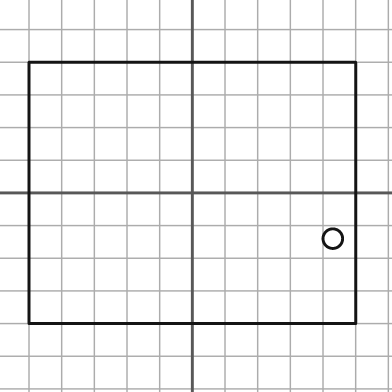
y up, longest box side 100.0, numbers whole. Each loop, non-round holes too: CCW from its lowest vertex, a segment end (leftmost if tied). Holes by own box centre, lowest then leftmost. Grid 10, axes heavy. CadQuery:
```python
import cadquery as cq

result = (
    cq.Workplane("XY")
    .moveTo(-50.0, -40.0)
    .lineTo(50.0, -40.0)
    .lineTo(50.0, 40.0)
    .lineTo(-50.0, 40.0)
    .close()
    .moveTo(43.0, -14.0)
    .circle(3.0)
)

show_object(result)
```